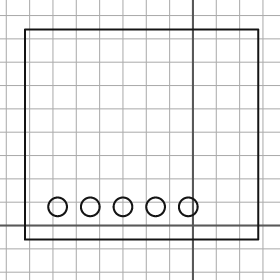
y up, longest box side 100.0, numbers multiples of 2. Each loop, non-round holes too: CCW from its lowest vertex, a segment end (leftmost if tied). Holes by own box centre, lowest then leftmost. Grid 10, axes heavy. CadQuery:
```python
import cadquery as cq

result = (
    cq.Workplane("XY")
    .moveTo(-72.0, -6.0)
    .lineTo(28.0, -6.0)
    .lineTo(28.0, 84.0)
    .lineTo(-72.0, 84.0)
    .close()
    .moveTo(-58.0, 8.0)
    .circle(4.0)
    .moveTo(-44.0, 8.0)
    .circle(4.0)
    .moveTo(-30.0, 8.0)
    .circle(4.0)
    .moveTo(-16.0, 8.0)
    .circle(4.0)
    .moveTo(-2.0, 8.0)
    .circle(4.0)
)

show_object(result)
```